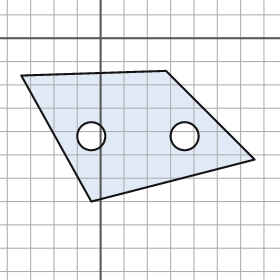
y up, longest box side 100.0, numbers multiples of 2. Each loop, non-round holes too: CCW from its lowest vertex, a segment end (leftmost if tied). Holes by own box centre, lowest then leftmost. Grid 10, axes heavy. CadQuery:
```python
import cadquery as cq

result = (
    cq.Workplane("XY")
    .moveTo(-4.0, -70.0)
    .lineTo(66.0, -52.0)
    .lineTo(28.0, -14.0)
    .lineTo(-34.0, -16.0)
    .close()
    .moveTo(-4.0, -42.0)
    .circle(6.0)
    .moveTo(36.0, -42.0)
    .circle(6.0)
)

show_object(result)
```